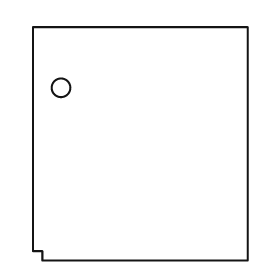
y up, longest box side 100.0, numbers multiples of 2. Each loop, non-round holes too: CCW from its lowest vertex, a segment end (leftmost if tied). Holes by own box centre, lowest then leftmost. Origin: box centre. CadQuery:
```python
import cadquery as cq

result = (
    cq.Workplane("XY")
    .moveTo(-42.0, -50.0)
    .lineTo(46.0, -50.0)
    .lineTo(46.0, 50.0)
    .lineTo(-46.0, 50.0)
    .lineTo(-46.0, -46.0)
    .lineTo(-42.0, -46.0)
    .close()
    .moveTo(-34.0, 24.0)
    .circle(4.0)
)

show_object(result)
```